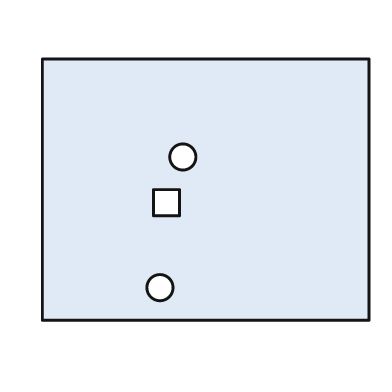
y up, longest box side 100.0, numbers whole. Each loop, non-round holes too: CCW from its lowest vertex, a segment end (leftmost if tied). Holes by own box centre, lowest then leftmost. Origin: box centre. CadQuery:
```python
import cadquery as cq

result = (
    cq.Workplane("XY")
    .moveTo(-50.0, -40.0)
    .lineTo(50.0, -40.0)
    .lineTo(50.0, 40.0)
    .lineTo(-50.0, 40.0)
    .close()
    .moveTo(-14.0, -30.0)
    .circle(4.0)
    .moveTo(-16.0, -8.0)
    .lineTo(-8.0, -8.0)
    .lineTo(-8.0, 0.0)
    .lineTo(-16.0, 0.0)
    .close()
    .moveTo(-7.0, 10.0)
    .circle(4.0)
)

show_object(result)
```